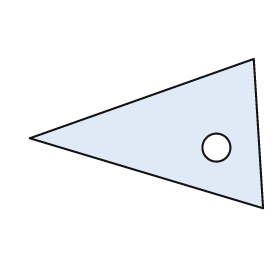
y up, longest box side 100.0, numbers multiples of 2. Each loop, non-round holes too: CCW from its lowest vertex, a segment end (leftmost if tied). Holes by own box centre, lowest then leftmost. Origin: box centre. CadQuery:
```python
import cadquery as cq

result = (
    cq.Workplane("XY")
    .moveTo(50.0, -32.0)
    .lineTo(46.0, 32.0)
    .lineTo(-50.0, -2.0)
    .close()
    .moveTo(30.0, -6.0)
    .circle(6.0)
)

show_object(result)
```